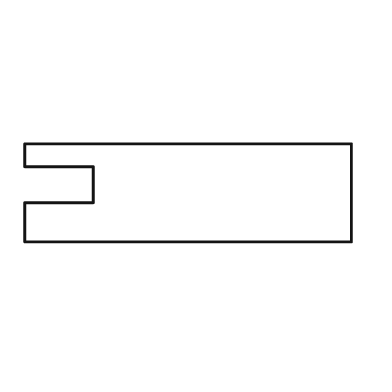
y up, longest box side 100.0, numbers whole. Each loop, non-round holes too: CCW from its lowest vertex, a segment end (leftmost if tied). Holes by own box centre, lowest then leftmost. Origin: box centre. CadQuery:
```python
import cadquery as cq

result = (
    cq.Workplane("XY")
    .moveTo(-50.0, -15.0)
    .lineTo(50.0, -15.0)
    .lineTo(50.0, 15.0)
    .lineTo(-50.0, 15.0)
    .lineTo(-50.0, 8.0)
    .lineTo(-29.0, 8.0)
    .lineTo(-29.0, -3.0)
    .lineTo(-50.0, -3.0)
    .close()
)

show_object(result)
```